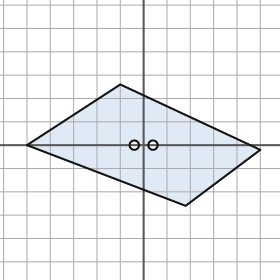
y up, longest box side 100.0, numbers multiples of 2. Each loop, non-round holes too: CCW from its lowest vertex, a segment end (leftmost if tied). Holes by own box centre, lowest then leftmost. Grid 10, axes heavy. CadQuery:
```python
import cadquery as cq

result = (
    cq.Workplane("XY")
    .moveTo(18.0, -26.0)
    .lineTo(50.0, -2.0)
    .lineTo(-10.0, 26.0)
    .lineTo(-50.0, 0.0)
    .close()
    .moveTo(-4.0, 0.0)
    .circle(2.0)
    .moveTo(4.0, 0.0)
    .circle(2.0)
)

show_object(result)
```